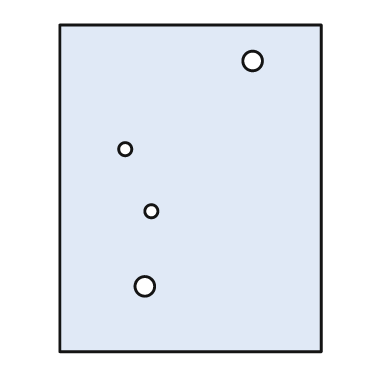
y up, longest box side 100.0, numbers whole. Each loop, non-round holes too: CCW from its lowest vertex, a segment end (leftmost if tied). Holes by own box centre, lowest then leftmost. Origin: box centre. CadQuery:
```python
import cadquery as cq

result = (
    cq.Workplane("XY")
    .moveTo(-40.0, -50.0)
    .lineTo(40.0, -50.0)
    .lineTo(40.0, 50.0)
    .lineTo(-40.0, 50.0)
    .close()
    .moveTo(-14.0, -30.0)
    .circle(3.0)
    .moveTo(-12.0, -7.0)
    .circle(2.0)
    .moveTo(-20.0, 12.0)
    .circle(2.0)
    .moveTo(19.0, 39.0)
    .circle(3.0)
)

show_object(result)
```